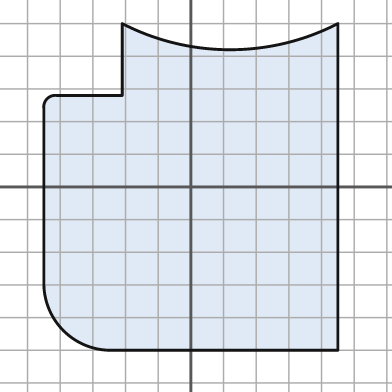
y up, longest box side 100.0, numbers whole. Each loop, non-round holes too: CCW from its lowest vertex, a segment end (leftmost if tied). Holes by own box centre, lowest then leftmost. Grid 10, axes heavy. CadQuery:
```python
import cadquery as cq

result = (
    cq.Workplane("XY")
    .moveTo(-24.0, -50.0)
    .lineTo(45.0, -50.0)
    .lineTo(45.0, 50.0)
    .threePointArc((12.0, 42.0), (-21.0, 50.0))
    .lineTo(-21.0, 28.0)
    .lineTo(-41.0, 28.0)
    .threePointArc((-44.0, 27.0), (-45.0, 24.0))
    .lineTo(-45.0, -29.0)
    .threePointArc((-39.0, -44.0), (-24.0, -50.0))
    .close()
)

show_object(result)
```